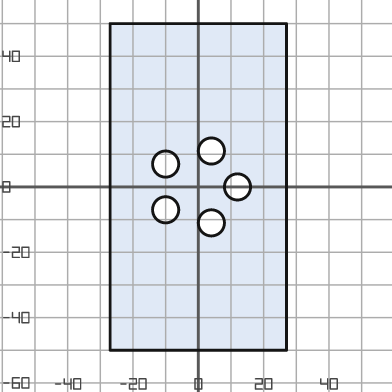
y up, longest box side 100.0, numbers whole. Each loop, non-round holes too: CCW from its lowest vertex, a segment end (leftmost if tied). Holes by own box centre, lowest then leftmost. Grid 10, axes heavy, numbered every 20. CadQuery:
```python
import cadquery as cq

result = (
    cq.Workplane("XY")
    .moveTo(-27.0, -50.0)
    .lineTo(27.0, -50.0)
    .lineTo(27.0, 50.0)
    .lineTo(-27.0, 50.0)
    .close()
    .moveTo(4.0, -11.0)
    .circle(4.0)
    .moveTo(-10.0, -7.0)
    .circle(4.0)
    .moveTo(12.0, 0.0)
    .circle(4.0)
    .moveTo(-10.0, 7.0)
    .circle(4.0)
    .moveTo(4.0, 11.0)
    .circle(4.0)
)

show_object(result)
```